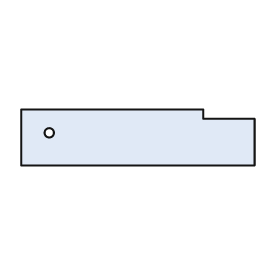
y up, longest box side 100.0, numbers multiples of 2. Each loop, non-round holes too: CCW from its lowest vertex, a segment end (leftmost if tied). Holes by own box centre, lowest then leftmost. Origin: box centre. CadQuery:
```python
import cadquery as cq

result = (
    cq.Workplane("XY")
    .moveTo(-50.0, -12.0)
    .lineTo(50.0, -12.0)
    .lineTo(50.0, 8.0)
    .lineTo(28.0, 8.0)
    .lineTo(28.0, 12.0)
    .lineTo(-50.0, 12.0)
    .close()
    .moveTo(-38.0, 2.0)
    .circle(2.0)
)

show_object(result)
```